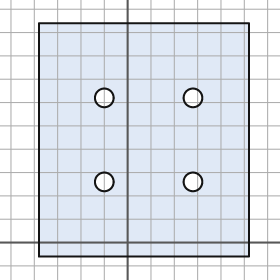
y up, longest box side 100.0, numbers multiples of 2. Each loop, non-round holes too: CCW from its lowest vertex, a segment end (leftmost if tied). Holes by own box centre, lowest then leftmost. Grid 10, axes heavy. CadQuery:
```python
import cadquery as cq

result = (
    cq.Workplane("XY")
    .moveTo(-38.0, -6.0)
    .lineTo(52.0, -6.0)
    .lineTo(52.0, 94.0)
    .lineTo(-38.0, 94.0)
    .close()
    .moveTo(-10.0, 26.0)
    .circle(4.0)
    .moveTo(28.0, 26.0)
    .circle(4.0)
    .moveTo(-10.0, 62.0)
    .circle(4.0)
    .moveTo(28.0, 62.0)
    .circle(4.0)
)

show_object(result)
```